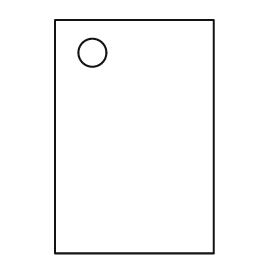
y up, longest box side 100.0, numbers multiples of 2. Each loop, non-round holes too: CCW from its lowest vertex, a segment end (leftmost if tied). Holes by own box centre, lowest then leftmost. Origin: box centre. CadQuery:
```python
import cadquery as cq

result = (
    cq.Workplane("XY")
    .moveTo(-34.0, -50.0)
    .lineTo(34.0, -50.0)
    .lineTo(34.0, 50.0)
    .lineTo(-34.0, 50.0)
    .close()
    .moveTo(-18.0, 36.0)
    .circle(6.0)
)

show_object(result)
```